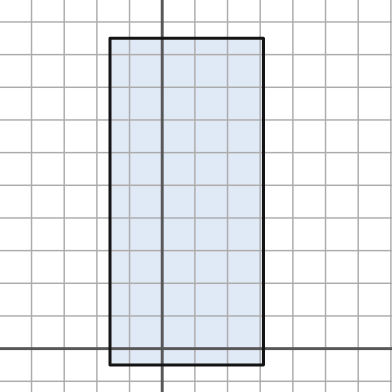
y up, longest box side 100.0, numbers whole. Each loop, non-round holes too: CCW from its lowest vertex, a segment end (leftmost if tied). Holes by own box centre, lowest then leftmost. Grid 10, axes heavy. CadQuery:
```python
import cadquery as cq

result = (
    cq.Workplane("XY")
    .moveTo(-16.0, -5.0)
    .lineTo(31.0, -5.0)
    .lineTo(31.0, 95.0)
    .lineTo(-16.0, 95.0)
    .close()
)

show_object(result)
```